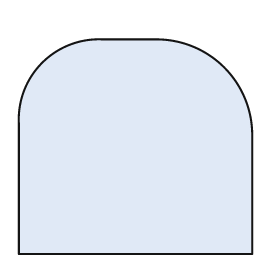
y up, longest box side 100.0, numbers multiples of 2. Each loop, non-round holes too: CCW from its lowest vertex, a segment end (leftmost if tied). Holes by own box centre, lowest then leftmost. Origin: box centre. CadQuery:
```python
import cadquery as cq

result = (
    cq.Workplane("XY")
    .moveTo(-50.0, -46.0)
    .lineTo(50.0, -46.0)
    .lineTo(50.0, 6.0)
    .threePointArc((38.0, 34.0), (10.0, 46.0))
    .lineTo(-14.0, 46.0)
    .threePointArc((-40.0, 36.0), (-50.0, 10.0))
    .close()
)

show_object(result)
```